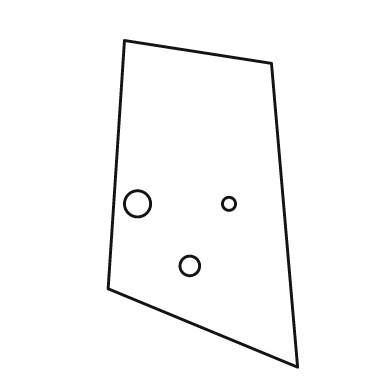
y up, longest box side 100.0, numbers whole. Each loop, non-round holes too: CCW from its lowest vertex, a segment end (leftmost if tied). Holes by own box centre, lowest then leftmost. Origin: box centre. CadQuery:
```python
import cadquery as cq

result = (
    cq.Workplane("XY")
    .moveTo(29.0, -50.0)
    .lineTo(21.0, 43.0)
    .lineTo(-24.0, 50.0)
    .lineTo(-29.0, -26.0)
    .close()
    .moveTo(-4.0, -19.0)
    .circle(3.0)
    .moveTo(-20.0, 0.0)
    .circle(4.0)
    .moveTo(8.0, 0.0)
    .circle(2.0)
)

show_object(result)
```